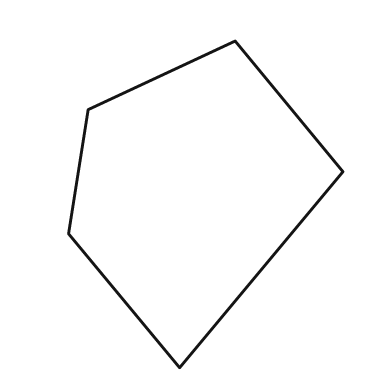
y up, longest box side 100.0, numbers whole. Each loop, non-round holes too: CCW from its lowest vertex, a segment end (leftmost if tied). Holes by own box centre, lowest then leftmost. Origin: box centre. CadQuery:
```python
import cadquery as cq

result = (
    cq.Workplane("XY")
    .moveTo(-8.0, -50.0)
    .lineTo(42.0, 10.0)
    .lineTo(9.0, 50.0)
    .lineTo(-36.0, 29.0)
    .lineTo(-42.0, -9.0)
    .close()
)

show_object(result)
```